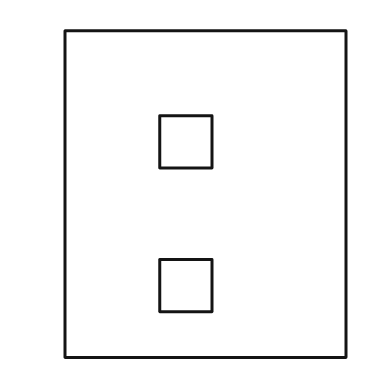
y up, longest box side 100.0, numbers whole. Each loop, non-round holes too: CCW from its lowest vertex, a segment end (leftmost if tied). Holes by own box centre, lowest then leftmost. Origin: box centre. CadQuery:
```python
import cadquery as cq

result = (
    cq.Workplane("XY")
    .moveTo(-43.0, -50.0)
    .lineTo(43.0, -50.0)
    .lineTo(43.0, 50.0)
    .lineTo(-43.0, 50.0)
    .close()
    .moveTo(-14.0, -36.0)
    .lineTo(2.0, -36.0)
    .lineTo(2.0, -20.0)
    .lineTo(-14.0, -20.0)
    .close()
    .moveTo(-14.0, 8.0)
    .lineTo(2.0, 8.0)
    .lineTo(2.0, 24.0)
    .lineTo(-14.0, 24.0)
    .close()
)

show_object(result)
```